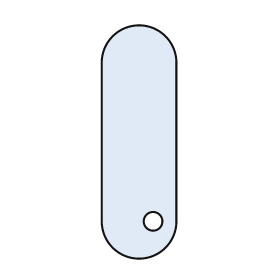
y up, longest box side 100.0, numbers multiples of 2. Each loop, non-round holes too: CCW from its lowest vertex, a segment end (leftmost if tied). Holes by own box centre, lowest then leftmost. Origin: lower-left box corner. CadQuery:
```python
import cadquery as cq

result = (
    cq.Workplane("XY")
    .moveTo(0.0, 16.0)
    .threePointArc((16.0, 0.0), (32.0, 16.0))
    .lineTo(32.0, 84.0)
    .threePointArc((16.0, 100.0), (0.0, 84.0))
    .close()
    .moveTo(22.0, 16.0)
    .circle(4.0)
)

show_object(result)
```